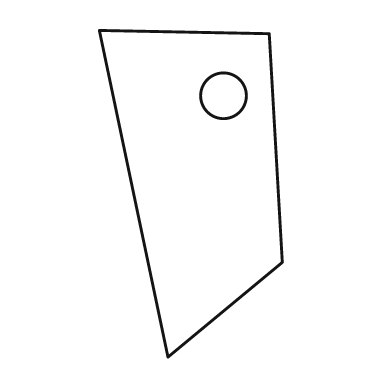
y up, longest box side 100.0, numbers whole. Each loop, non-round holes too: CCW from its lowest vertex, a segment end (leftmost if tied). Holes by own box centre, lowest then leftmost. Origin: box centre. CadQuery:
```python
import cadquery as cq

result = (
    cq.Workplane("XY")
    .moveTo(-7.0, -50.0)
    .lineTo(28.0, -21.0)
    .lineTo(24.0, 49.0)
    .lineTo(-28.0, 50.0)
    .close()
    .moveTo(10.0, 30.0)
    .circle(7.0)
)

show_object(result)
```